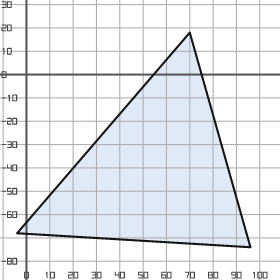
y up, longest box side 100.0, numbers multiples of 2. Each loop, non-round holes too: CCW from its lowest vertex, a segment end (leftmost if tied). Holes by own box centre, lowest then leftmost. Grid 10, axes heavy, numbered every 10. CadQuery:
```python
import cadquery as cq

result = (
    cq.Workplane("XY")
    .moveTo(96.0, -74.0)
    .lineTo(70.0, 18.0)
    .lineTo(-4.0, -68.0)
    .close()
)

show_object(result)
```